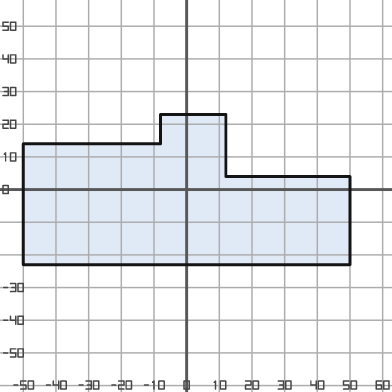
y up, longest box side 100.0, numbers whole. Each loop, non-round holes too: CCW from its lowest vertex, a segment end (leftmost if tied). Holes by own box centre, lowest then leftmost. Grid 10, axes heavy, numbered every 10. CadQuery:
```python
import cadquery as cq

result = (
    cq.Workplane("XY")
    .moveTo(-50.0, -23.0)
    .lineTo(50.0, -23.0)
    .lineTo(50.0, 4.0)
    .lineTo(12.0, 4.0)
    .lineTo(12.0, 23.0)
    .lineTo(-8.0, 23.0)
    .lineTo(-8.0, 14.0)
    .lineTo(-50.0, 14.0)
    .close()
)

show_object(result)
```